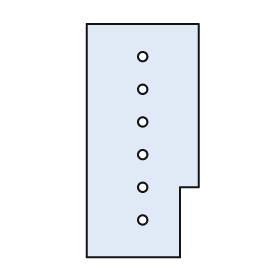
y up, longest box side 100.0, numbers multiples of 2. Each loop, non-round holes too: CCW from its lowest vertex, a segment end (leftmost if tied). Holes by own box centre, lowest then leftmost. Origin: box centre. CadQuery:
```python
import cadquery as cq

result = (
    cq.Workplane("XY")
    .moveTo(-24.0, -50.0)
    .lineTo(16.0, -50.0)
    .lineTo(16.0, -20.0)
    .lineTo(24.0, -20.0)
    .lineTo(24.0, 50.0)
    .lineTo(-24.0, 50.0)
    .close()
    .moveTo(0.0, -34.0)
    .circle(2.0)
    .moveTo(0.0, -20.0)
    .circle(2.0)
    .moveTo(0.0, -6.0)
    .circle(2.0)
    .moveTo(0.0, 8.0)
    .circle(2.0)
    .moveTo(0.0, 22.0)
    .circle(2.0)
    .moveTo(0.0, 36.0)
    .circle(2.0)
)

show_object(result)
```